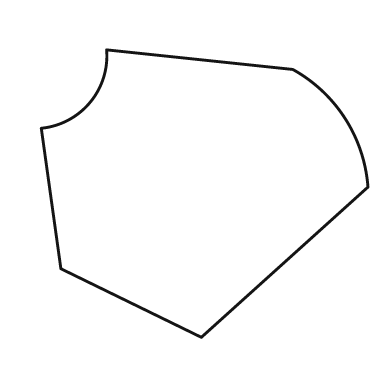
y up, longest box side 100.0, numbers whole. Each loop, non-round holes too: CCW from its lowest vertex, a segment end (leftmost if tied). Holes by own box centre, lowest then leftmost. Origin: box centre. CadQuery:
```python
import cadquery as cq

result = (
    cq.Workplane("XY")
    .moveTo(-1.0, -44.0)
    .lineTo(50.0, 2.0)
    .threePointArc((43.0, 23.0), (27.0, 38.0))
    .lineTo(-30.0, 44.0)
    .threePointArc((-35.0, 28.0), (-50.0, 20.0))
    .lineTo(-44.0, -23.0)
    .close()
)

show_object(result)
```